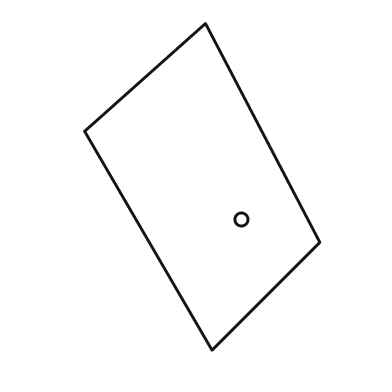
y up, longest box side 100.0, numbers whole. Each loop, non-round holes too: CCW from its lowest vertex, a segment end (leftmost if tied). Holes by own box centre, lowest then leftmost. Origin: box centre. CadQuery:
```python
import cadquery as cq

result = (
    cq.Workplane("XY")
    .moveTo(3.0, -50.0)
    .lineTo(36.0, -17.0)
    .lineTo(1.0, 50.0)
    .lineTo(-36.0, 17.0)
    .close()
    .moveTo(12.0, -10.0)
    .circle(2.0)
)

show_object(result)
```